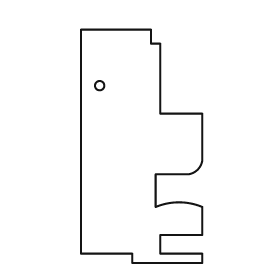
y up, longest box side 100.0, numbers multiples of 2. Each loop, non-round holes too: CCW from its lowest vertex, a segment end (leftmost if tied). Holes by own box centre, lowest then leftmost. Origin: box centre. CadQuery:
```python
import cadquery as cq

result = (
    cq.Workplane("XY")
    .moveTo(-4.0, -50.0)
    .lineTo(26.0, -50.0)
    .lineTo(26.0, -46.0)
    .lineTo(8.0, -46.0)
    .lineTo(8.0, -38.0)
    .lineTo(26.0, -38.0)
    .lineTo(26.0, -26.0)
    .threePointArc((16.0, -24.0), (6.0, -26.0))
    .lineTo(6.0, -12.0)
    .lineTo(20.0, -12.0)
    .threePointArc((24.0, -10.0), (26.0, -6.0))
    .lineTo(26.0, 14.0)
    .lineTo(8.0, 14.0)
    .lineTo(8.0, 44.0)
    .lineTo(4.0, 44.0)
    .lineTo(4.0, 50.0)
    .lineTo(-26.0, 50.0)
    .lineTo(-26.0, -46.0)
    .lineTo(-4.0, -46.0)
    .close()
    .moveTo(-18.0, 26.0)
    .circle(2.0)
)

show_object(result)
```